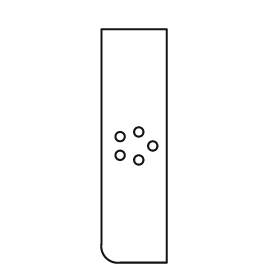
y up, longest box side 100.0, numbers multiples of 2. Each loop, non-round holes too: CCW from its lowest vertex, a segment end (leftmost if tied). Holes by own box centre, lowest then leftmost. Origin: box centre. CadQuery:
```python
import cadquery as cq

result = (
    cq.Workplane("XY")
    .moveTo(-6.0, -50.0)
    .lineTo(14.0, -50.0)
    .lineTo(14.0, 50.0)
    .lineTo(-14.0, 50.0)
    .lineTo(-14.0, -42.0)
    .threePointArc((-12.0, -48.0), (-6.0, -50.0))
    .close()
    .moveTo(2.0, -6.0)
    .circle(2.0)
    .moveTo(-6.0, -4.0)
    .circle(2.0)
    .moveTo(8.0, 0.0)
    .circle(2.0)
    .moveTo(-6.0, 4.0)
    .circle(2.0)
    .moveTo(2.0, 6.0)
    .circle(2.0)
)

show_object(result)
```